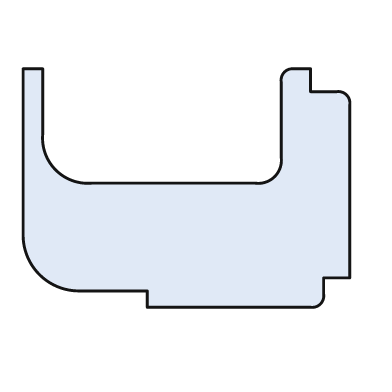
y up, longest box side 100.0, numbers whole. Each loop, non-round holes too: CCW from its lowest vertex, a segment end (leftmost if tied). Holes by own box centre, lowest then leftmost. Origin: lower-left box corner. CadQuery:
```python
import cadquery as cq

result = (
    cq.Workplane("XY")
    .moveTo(38.0, 0.0)
    .lineTo(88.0, 0.0)
    .threePointArc((91.0, 1.0), (92.0, 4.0))
    .lineTo(92.0, 9.0)
    .lineTo(100.0, 9.0)
    .lineTo(100.0, 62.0)
    .threePointArc((99.0, 65.0), (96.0, 66.0))
    .lineTo(88.0, 66.0)
    .lineTo(88.0, 73.0)
    .lineTo(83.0, 73.0)
    .threePointArc((80.0, 72.0), (79.0, 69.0))
    .lineTo(79.0, 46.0)
    .threePointArc((77.0, 40.0), (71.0, 38.0))
    .lineTo(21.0, 38.0)
    .threePointArc((10.0, 42.0), (6.0, 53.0))
    .lineTo(6.0, 73.0)
    .lineTo(0.0, 73.0)
    .lineTo(0.0, 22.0)
    .threePointArc((5.0, 10.0), (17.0, 5.0))
    .lineTo(38.0, 5.0)
    .close()
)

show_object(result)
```